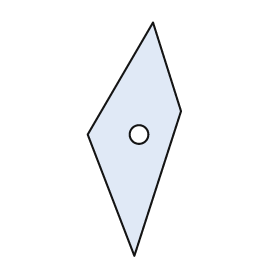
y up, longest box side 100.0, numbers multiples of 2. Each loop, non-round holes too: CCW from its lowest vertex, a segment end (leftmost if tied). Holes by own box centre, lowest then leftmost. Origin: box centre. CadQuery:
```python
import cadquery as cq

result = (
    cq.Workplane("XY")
    .moveTo(0.0, -50.0)
    .lineTo(20.0, 12.0)
    .lineTo(8.0, 50.0)
    .lineTo(-20.0, 2.0)
    .close()
    .moveTo(2.0, 2.0)
    .circle(4.0)
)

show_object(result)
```